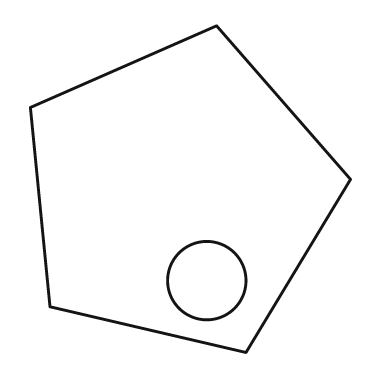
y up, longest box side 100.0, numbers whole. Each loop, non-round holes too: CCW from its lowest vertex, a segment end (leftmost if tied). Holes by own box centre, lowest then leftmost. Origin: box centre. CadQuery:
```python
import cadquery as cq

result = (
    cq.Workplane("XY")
    .moveTo(17.0, -50.0)
    .lineTo(49.0, 3.0)
    .lineTo(8.0, 50.0)
    .lineTo(-49.0, 25.0)
    .lineTo(-43.0, -36.0)
    .close()
    .moveTo(5.0, -28.0)
    .circle(12.0)
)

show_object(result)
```